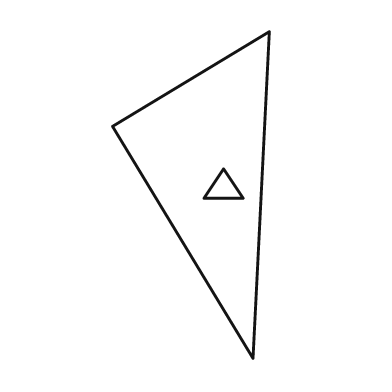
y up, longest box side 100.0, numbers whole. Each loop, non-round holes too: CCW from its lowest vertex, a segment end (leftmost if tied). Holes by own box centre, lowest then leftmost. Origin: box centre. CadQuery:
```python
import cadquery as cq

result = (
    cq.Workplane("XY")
    .moveTo(19.0, -50.0)
    .lineTo(24.0, 50.0)
    .lineTo(-24.0, 21.0)
    .close()
    .moveTo(4.0, -1.0)
    .lineTo(16.0, -1.0)
    .lineTo(10.0, 8.0)
    .close()
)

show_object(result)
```